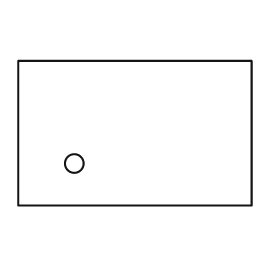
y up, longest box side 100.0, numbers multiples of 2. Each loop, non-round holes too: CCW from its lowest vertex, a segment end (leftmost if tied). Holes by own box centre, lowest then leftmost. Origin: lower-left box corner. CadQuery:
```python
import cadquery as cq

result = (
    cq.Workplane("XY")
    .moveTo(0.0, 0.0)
    .lineTo(100.0, 0.0)
    .lineTo(100.0, 62.0)
    .lineTo(0.0, 62.0)
    .close()
    .moveTo(24.0, 18.0)
    .circle(4.0)
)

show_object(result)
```